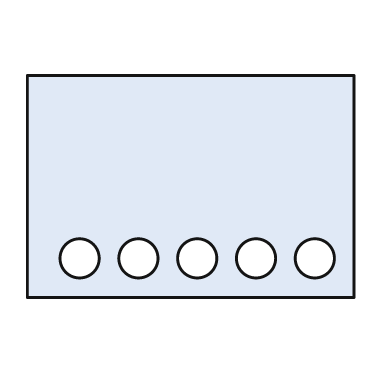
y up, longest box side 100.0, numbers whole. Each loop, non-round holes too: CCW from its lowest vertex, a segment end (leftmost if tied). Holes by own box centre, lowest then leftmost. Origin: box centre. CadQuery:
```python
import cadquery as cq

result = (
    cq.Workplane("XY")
    .moveTo(-50.0, -34.0)
    .lineTo(50.0, -34.0)
    .lineTo(50.0, 34.0)
    .lineTo(-50.0, 34.0)
    .close()
    .moveTo(-34.0, -22.0)
    .circle(6.0)
    .moveTo(-16.0, -22.0)
    .circle(6.0)
    .moveTo(2.0, -22.0)
    .circle(6.0)
    .moveTo(20.0, -22.0)
    .circle(6.0)
    .moveTo(38.0, -22.0)
    .circle(6.0)
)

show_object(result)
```